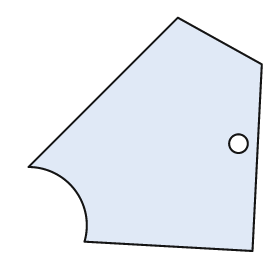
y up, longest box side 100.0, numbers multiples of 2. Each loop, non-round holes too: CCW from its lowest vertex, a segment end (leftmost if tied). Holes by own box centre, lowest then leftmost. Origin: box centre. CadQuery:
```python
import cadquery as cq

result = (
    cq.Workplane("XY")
    .moveTo(46.0, -50.0)
    .lineTo(50.0, 30.0)
    .lineTo(14.0, 50.0)
    .lineTo(-50.0, -14.0)
    .threePointArc((-30.0, -24.0), (-26.0, -46.0))
    .close()
    .moveTo(40.0, -4.0)
    .circle(4.0)
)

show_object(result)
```